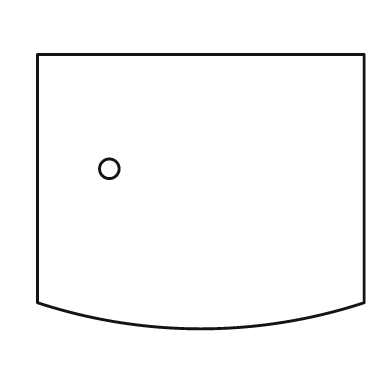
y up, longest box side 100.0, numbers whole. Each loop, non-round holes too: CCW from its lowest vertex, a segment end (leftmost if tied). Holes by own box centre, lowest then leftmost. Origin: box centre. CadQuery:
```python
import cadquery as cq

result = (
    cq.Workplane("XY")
    .moveTo(-50.0, -34.0)
    .threePointArc((0.0, -42.0), (50.0, -34.0))
    .lineTo(50.0, 42.0)
    .lineTo(-50.0, 42.0)
    .close()
    .moveTo(-28.0, 7.0)
    .circle(3.0)
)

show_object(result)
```